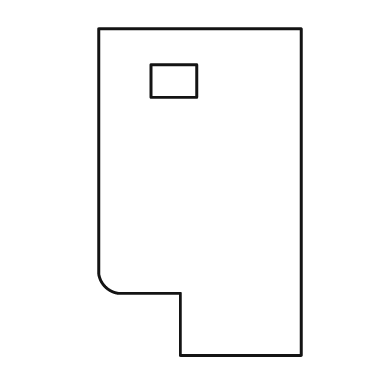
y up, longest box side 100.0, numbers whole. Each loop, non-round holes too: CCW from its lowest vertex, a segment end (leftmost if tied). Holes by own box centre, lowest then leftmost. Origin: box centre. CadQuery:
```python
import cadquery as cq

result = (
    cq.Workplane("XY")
    .moveTo(-6.0, -50.0)
    .lineTo(31.0, -50.0)
    .lineTo(31.0, 50.0)
    .lineTo(-31.0, 50.0)
    .lineTo(-31.0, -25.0)
    .threePointArc((-29.0, -29.0), (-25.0, -31.0))
    .lineTo(-6.0, -31.0)
    .close()
    .moveTo(-15.0, 29.0)
    .lineTo(-1.0, 29.0)
    .lineTo(-1.0, 39.0)
    .lineTo(-15.0, 39.0)
    .close()
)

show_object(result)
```